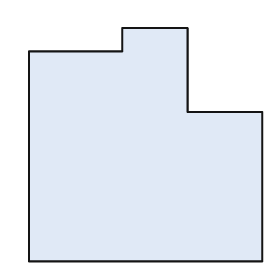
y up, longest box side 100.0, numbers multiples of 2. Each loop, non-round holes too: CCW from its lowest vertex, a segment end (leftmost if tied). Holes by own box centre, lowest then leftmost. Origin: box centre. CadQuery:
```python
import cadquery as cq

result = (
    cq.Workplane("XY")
    .moveTo(-50.0, -50.0)
    .lineTo(50.0, -50.0)
    .lineTo(50.0, 14.0)
    .lineTo(18.0, 14.0)
    .lineTo(18.0, 50.0)
    .lineTo(-10.0, 50.0)
    .lineTo(-10.0, 40.0)
    .lineTo(-50.0, 40.0)
    .close()
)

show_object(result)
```